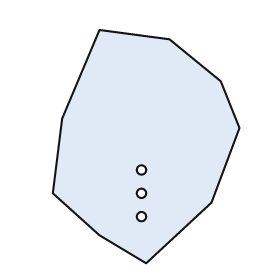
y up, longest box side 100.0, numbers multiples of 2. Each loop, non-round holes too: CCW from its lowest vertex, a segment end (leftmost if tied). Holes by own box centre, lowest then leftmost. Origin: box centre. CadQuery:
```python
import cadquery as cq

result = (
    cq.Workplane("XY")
    .moveTo(0.0, -50.0)
    .lineTo(28.0, -24.0)
    .lineTo(40.0, 8.0)
    .lineTo(32.0, 28.0)
    .lineTo(10.0, 46.0)
    .lineTo(-20.0, 50.0)
    .lineTo(-36.0, 12.0)
    .lineTo(-40.0, -20.0)
    .lineTo(-20.0, -38.0)
    .close()
    .moveTo(-2.0, -30.0)
    .circle(2.0)
    .moveTo(-2.0, -20.0)
    .circle(2.0)
    .moveTo(-2.0, -10.0)
    .circle(2.0)
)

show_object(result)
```